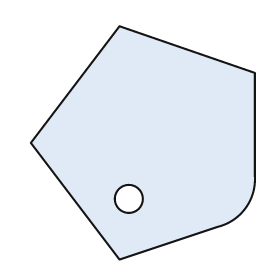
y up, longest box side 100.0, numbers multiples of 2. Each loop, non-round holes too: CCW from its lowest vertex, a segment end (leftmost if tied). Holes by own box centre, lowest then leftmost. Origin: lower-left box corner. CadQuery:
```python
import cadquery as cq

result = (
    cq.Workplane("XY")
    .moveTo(38.0, 0.0)
    .lineTo(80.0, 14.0)
    .threePointArc((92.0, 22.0), (96.0, 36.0))
    .lineTo(96.0, 80.0)
    .lineTo(38.0, 100.0)
    .lineTo(0.0, 50.0)
    .close()
    .moveTo(42.0, 26.0)
    .circle(6.0)
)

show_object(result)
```